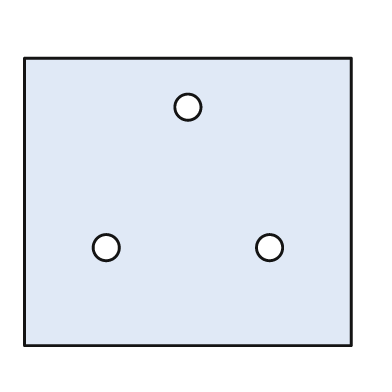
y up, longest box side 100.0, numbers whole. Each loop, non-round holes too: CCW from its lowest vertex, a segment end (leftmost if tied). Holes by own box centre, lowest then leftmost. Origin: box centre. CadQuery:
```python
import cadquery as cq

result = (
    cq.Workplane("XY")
    .moveTo(-50.0, -44.0)
    .lineTo(50.0, -44.0)
    .lineTo(50.0, 44.0)
    .lineTo(-50.0, 44.0)
    .close()
    .moveTo(-25.0, -14.0)
    .circle(4.0)
    .moveTo(25.0, -14.0)
    .circle(4.0)
    .moveTo(0.0, 29.0)
    .circle(4.0)
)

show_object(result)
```